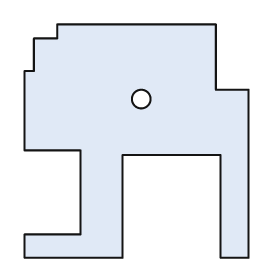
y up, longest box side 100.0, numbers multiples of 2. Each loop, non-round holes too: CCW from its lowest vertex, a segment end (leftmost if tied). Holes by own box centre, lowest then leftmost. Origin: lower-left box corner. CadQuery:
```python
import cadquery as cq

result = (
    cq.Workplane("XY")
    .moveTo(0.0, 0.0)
    .lineTo(42.0, 0.0)
    .lineTo(42.0, 44.0)
    .lineTo(84.0, 44.0)
    .lineTo(84.0, 0.0)
    .lineTo(96.0, 0.0)
    .lineTo(96.0, 72.0)
    .lineTo(82.0, 72.0)
    .lineTo(82.0, 100.0)
    .lineTo(14.0, 100.0)
    .lineTo(14.0, 94.0)
    .lineTo(4.0, 94.0)
    .lineTo(4.0, 80.0)
    .lineTo(0.0, 80.0)
    .lineTo(0.0, 46.0)
    .lineTo(24.0, 46.0)
    .lineTo(24.0, 10.0)
    .lineTo(0.0, 10.0)
    .close()
    .moveTo(50.0, 68.0)
    .circle(4.0)
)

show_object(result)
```